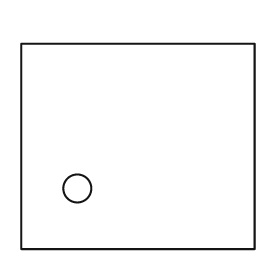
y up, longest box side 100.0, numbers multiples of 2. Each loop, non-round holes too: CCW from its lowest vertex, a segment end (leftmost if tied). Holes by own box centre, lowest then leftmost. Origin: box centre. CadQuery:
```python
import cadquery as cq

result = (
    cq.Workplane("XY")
    .moveTo(-50.0, -44.0)
    .lineTo(50.0, -44.0)
    .lineTo(50.0, 44.0)
    .lineTo(-50.0, 44.0)
    .close()
    .moveTo(-26.0, -18.0)
    .circle(6.0)
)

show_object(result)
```